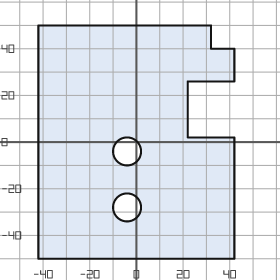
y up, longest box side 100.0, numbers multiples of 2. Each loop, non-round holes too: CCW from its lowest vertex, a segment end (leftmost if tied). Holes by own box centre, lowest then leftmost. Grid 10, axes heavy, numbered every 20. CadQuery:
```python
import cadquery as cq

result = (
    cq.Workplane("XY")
    .moveTo(-42.0, -50.0)
    .lineTo(42.0, -50.0)
    .lineTo(42.0, 2.0)
    .lineTo(22.0, 2.0)
    .lineTo(22.0, 26.0)
    .lineTo(42.0, 26.0)
    .lineTo(42.0, 40.0)
    .lineTo(32.0, 40.0)
    .lineTo(32.0, 50.0)
    .lineTo(-42.0, 50.0)
    .close()
    .moveTo(-4.0, -28.0)
    .circle(6.0)
    .moveTo(-4.0, -4.0)
    .circle(6.0)
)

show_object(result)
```